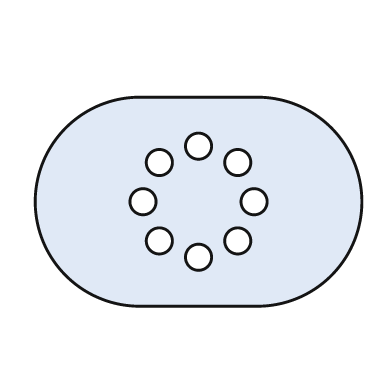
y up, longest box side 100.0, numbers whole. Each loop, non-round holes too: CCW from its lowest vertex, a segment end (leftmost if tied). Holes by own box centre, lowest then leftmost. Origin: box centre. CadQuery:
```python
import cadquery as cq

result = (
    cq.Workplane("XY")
    .moveTo(-18.0, -32.0)
    .lineTo(18.0, -32.0)
    .threePointArc((50.0, 0.0), (18.0, 32.0))
    .lineTo(-18.0, 32.0)
    .threePointArc((-50.0, 0.0), (-18.0, -32.0))
    .close()
    .moveTo(0.0, -17.0)
    .circle(4.0)
    .moveTo(-12.0, -12.0)
    .circle(4.0)
    .moveTo(12.0, -12.0)
    .circle(4.0)
    .moveTo(-17.0, 0.0)
    .circle(4.0)
    .moveTo(17.0, 0.0)
    .circle(4.0)
    .moveTo(-12.0, 12.0)
    .circle(4.0)
    .moveTo(12.0, 12.0)
    .circle(4.0)
    .moveTo(0.0, 17.0)
    .circle(4.0)
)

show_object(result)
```